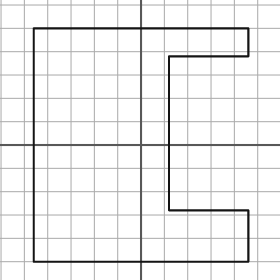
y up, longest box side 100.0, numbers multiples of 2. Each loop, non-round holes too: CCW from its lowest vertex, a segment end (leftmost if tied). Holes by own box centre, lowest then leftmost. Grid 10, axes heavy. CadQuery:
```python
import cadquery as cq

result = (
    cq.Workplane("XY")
    .moveTo(-46.0, -50.0)
    .lineTo(46.0, -50.0)
    .lineTo(46.0, -28.0)
    .lineTo(12.0, -28.0)
    .lineTo(12.0, 38.0)
    .lineTo(46.0, 38.0)
    .lineTo(46.0, 50.0)
    .lineTo(-46.0, 50.0)
    .close()
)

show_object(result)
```